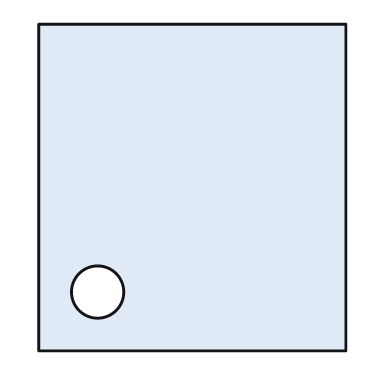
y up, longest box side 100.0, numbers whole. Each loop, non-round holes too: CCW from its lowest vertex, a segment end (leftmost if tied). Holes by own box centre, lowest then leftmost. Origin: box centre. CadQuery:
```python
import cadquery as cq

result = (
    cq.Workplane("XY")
    .moveTo(-47.0, -50.0)
    .lineTo(47.0, -50.0)
    .lineTo(47.0, 50.0)
    .lineTo(-47.0, 50.0)
    .close()
    .moveTo(-29.0, -32.0)
    .circle(8.0)
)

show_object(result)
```